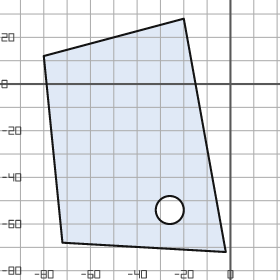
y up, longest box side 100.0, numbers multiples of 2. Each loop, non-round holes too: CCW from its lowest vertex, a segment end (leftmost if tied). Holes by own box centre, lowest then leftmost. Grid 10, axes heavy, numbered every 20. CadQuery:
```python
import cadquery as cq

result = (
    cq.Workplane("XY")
    .moveTo(-2.0, -72.0)
    .lineTo(-20.0, 28.0)
    .lineTo(-80.0, 12.0)
    .lineTo(-72.0, -68.0)
    .close()
    .moveTo(-26.0, -54.0)
    .circle(6.0)
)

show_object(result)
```